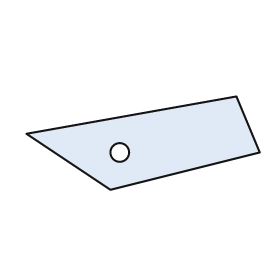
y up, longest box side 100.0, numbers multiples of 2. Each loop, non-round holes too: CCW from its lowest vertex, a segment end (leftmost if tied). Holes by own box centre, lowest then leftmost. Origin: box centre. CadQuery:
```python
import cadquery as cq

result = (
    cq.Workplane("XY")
    .moveTo(-14.0, -20.0)
    .lineTo(50.0, -4.0)
    .lineTo(40.0, 20.0)
    .lineTo(-50.0, 4.0)
    .close()
    .moveTo(-10.0, -4.0)
    .circle(4.0)
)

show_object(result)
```